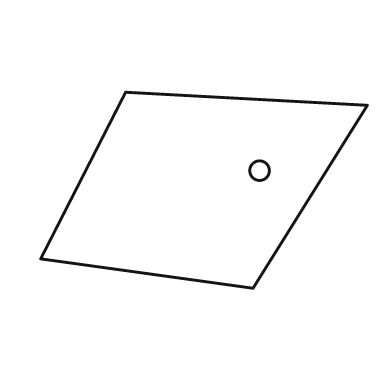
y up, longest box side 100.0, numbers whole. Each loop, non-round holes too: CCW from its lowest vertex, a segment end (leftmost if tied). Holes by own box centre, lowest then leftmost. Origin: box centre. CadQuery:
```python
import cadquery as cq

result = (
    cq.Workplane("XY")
    .moveTo(15.0, -30.0)
    .lineTo(50.0, 26.0)
    .lineTo(-24.0, 30.0)
    .lineTo(-50.0, -21.0)
    .close()
    .moveTo(17.0, 6.0)
    .circle(3.0)
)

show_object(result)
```